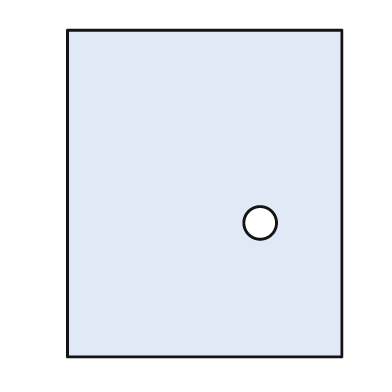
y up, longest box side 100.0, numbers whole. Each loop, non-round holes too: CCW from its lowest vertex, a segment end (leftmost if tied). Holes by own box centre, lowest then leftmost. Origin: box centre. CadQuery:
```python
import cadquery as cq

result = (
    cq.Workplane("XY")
    .moveTo(-42.0, -50.0)
    .lineTo(42.0, -50.0)
    .lineTo(42.0, 50.0)
    .lineTo(-42.0, 50.0)
    .close()
    .moveTo(17.0, -9.0)
    .circle(5.0)
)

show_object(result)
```